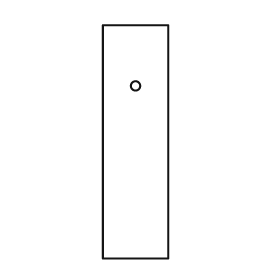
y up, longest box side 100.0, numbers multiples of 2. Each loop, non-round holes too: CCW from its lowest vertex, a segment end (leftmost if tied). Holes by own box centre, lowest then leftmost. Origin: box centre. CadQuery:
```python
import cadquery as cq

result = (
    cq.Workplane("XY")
    .moveTo(-14.0, -50.0)
    .lineTo(14.0, -50.0)
    .lineTo(14.0, 50.0)
    .lineTo(-14.0, 50.0)
    .close()
    .moveTo(0.0, 24.0)
    .circle(2.0)
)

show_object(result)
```